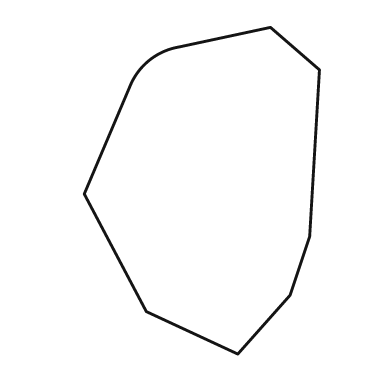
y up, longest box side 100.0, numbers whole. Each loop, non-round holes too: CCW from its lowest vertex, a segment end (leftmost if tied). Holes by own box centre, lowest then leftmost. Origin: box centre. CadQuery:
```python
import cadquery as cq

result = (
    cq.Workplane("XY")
    .moveTo(11.0, -50.0)
    .lineTo(27.0, -32.0)
    .lineTo(33.0, -14.0)
    .lineTo(36.0, 37.0)
    .lineTo(21.0, 50.0)
    .lineTo(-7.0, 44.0)
    .threePointArc((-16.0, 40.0), (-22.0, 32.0))
    .lineTo(-36.0, -1.0)
    .lineTo(-17.0, -37.0)
    .close()
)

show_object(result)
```